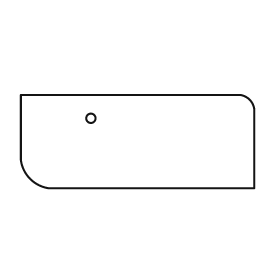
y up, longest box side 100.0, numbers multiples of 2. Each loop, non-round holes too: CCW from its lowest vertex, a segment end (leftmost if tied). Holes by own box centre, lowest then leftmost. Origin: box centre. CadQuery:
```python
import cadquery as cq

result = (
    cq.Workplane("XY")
    .moveTo(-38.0, -20.0)
    .lineTo(50.0, -20.0)
    .lineTo(50.0, 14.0)
    .threePointArc((48.0, 18.0), (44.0, 20.0))
    .lineTo(-50.0, 20.0)
    .lineTo(-50.0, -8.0)
    .threePointArc((-46.0, -16.0), (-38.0, -20.0))
    .close()
    .moveTo(-20.0, 10.0)
    .circle(2.0)
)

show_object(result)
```